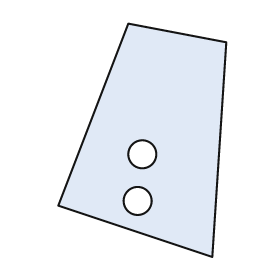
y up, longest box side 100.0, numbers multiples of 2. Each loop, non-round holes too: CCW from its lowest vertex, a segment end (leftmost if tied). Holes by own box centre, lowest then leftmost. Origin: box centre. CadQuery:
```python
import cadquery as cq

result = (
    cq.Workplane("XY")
    .moveTo(30.0, -50.0)
    .lineTo(36.0, 42.0)
    .lineTo(-6.0, 50.0)
    .lineTo(-36.0, -28.0)
    .close()
    .moveTo(-2.0, -26.0)
    .circle(6.0)
    .moveTo(0.0, -6.0)
    .circle(6.0)
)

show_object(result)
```